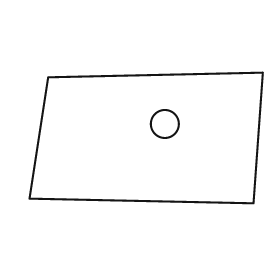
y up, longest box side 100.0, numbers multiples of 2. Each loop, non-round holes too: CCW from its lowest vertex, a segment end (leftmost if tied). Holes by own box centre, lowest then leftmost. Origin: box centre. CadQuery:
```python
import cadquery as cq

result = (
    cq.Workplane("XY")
    .moveTo(46.0, -28.0)
    .lineTo(50.0, 28.0)
    .lineTo(-42.0, 26.0)
    .lineTo(-50.0, -26.0)
    .close()
    .moveTo(8.0, 6.0)
    .circle(6.0)
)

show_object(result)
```